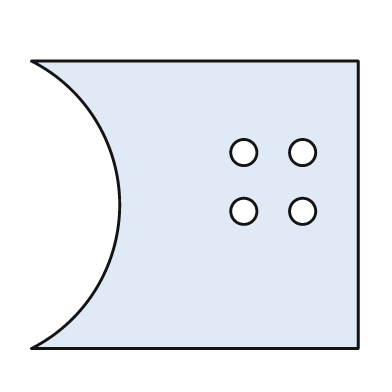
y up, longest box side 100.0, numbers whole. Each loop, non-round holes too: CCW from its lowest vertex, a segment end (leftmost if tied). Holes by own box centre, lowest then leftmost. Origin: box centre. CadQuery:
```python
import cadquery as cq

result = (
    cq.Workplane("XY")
    .moveTo(-50.0, -44.0)
    .lineTo(50.0, -44.0)
    .lineTo(50.0, 44.0)
    .lineTo(-50.0, 44.0)
    .threePointArc((-23.0, 0.0), (-50.0, -44.0))
    .close()
    .moveTo(15.0, -2.0)
    .circle(4.0)
    .moveTo(33.0, -2.0)
    .circle(4.0)
    .moveTo(15.0, 16.0)
    .circle(4.0)
    .moveTo(33.0, 16.0)
    .circle(4.0)
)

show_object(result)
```